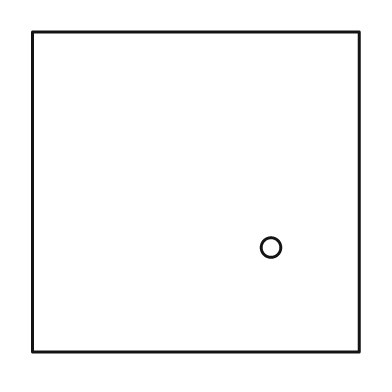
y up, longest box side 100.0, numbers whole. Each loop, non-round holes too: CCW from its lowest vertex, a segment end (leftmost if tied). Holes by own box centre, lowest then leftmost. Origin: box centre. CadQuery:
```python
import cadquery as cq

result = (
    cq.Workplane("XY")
    .moveTo(-50.0, -49.0)
    .lineTo(50.0, -49.0)
    .lineTo(50.0, 49.0)
    .lineTo(-50.0, 49.0)
    .close()
    .moveTo(23.0, -17.0)
    .circle(3.0)
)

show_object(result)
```